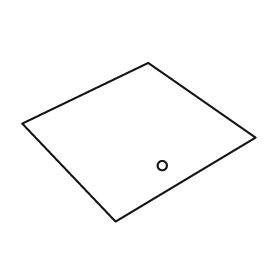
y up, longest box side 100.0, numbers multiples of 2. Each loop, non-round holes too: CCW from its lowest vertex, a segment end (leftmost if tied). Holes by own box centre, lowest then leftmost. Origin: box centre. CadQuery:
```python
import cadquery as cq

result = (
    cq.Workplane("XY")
    .moveTo(-10.0, -34.0)
    .lineTo(50.0, 2.0)
    .lineTo(4.0, 34.0)
    .lineTo(-50.0, 8.0)
    .close()
    .moveTo(10.0, -10.0)
    .circle(2.0)
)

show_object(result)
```